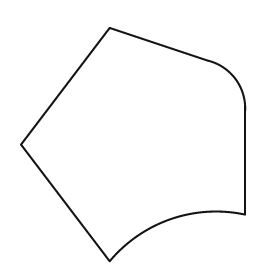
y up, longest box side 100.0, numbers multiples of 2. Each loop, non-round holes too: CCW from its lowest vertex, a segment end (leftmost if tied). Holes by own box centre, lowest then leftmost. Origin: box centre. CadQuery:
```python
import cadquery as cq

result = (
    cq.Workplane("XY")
    .moveTo(-10.0, -50.0)
    .threePointArc((16.0, -32.0), (48.0, -30.0))
    .lineTo(48.0, 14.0)
    .threePointArc((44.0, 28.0), (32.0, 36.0))
    .lineTo(-10.0, 50.0)
    .lineTo(-48.0, 0.0)
    .close()
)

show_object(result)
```